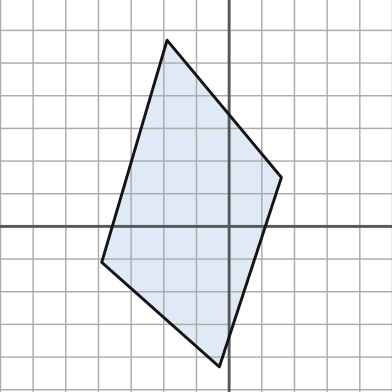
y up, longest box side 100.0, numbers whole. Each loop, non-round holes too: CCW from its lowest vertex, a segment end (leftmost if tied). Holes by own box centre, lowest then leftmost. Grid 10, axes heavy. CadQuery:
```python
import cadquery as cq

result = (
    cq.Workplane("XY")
    .moveTo(-3.0, -43.0)
    .lineTo(16.0, 15.0)
    .lineTo(-19.0, 57.0)
    .lineTo(-39.0, -11.0)
    .close()
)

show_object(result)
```